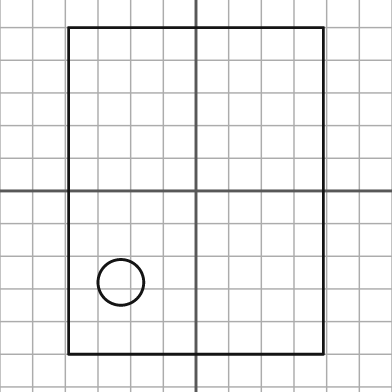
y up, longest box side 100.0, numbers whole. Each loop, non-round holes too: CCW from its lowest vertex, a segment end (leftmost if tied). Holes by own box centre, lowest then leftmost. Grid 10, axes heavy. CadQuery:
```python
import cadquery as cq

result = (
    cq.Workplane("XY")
    .moveTo(-39.0, -50.0)
    .lineTo(39.0, -50.0)
    .lineTo(39.0, 50.0)
    .lineTo(-39.0, 50.0)
    .close()
    .moveTo(-23.0, -28.0)
    .circle(7.0)
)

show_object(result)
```